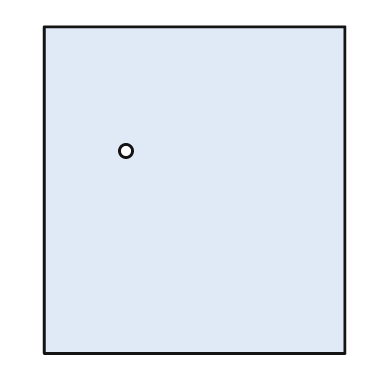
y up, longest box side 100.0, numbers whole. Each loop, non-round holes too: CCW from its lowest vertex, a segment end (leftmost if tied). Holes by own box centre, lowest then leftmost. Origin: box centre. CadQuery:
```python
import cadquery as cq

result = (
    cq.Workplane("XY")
    .moveTo(-46.0, -50.0)
    .lineTo(46.0, -50.0)
    .lineTo(46.0, 50.0)
    .lineTo(-46.0, 50.0)
    .close()
    .moveTo(-21.0, 12.0)
    .circle(2.0)
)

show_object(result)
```